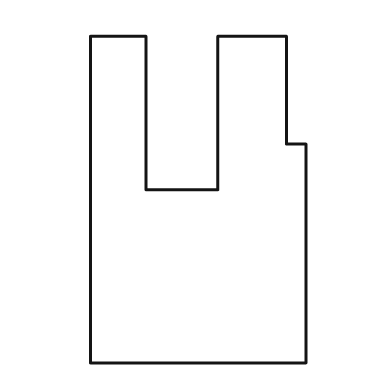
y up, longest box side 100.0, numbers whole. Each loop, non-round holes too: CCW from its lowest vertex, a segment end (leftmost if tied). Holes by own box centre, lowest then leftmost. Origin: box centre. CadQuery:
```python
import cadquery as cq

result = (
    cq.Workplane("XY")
    .moveTo(-33.0, -50.0)
    .lineTo(33.0, -50.0)
    .lineTo(33.0, 17.0)
    .lineTo(27.0, 17.0)
    .lineTo(27.0, 50.0)
    .lineTo(6.0, 50.0)
    .lineTo(6.0, 3.0)
    .lineTo(-16.0, 3.0)
    .lineTo(-16.0, 50.0)
    .lineTo(-33.0, 50.0)
    .close()
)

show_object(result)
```